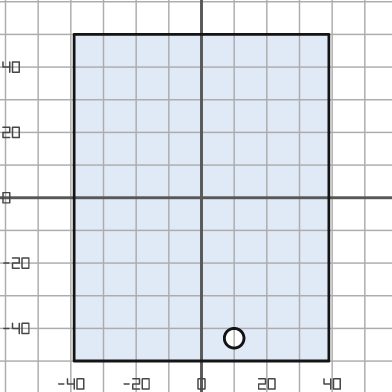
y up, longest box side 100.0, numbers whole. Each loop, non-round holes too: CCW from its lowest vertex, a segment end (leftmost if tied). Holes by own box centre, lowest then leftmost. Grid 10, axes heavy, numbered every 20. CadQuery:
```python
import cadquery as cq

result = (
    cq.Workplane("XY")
    .moveTo(-39.0, -50.0)
    .lineTo(39.0, -50.0)
    .lineTo(39.0, 50.0)
    .lineTo(-39.0, 50.0)
    .close()
    .moveTo(10.0, -43.0)
    .circle(3.0)
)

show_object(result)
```